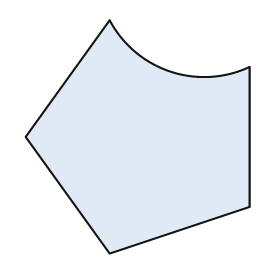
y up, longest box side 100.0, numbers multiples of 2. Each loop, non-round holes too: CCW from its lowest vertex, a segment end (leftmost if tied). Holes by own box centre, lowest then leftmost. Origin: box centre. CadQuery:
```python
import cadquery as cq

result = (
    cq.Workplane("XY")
    .moveTo(-12.0, -50.0)
    .lineTo(48.0, -30.0)
    .lineTo(48.0, 30.0)
    .threePointArc((14.0, 28.0), (-12.0, 50.0))
    .lineTo(-48.0, 0.0)
    .close()
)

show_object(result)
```